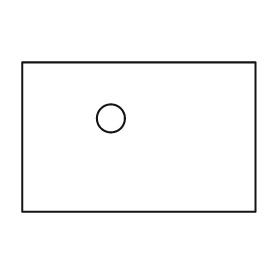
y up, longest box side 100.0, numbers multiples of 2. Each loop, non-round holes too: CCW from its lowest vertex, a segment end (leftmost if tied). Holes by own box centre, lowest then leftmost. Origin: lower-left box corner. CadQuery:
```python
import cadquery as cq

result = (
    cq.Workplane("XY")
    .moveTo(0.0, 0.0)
    .lineTo(100.0, 0.0)
    .lineTo(100.0, 64.0)
    .lineTo(0.0, 64.0)
    .close()
    .moveTo(38.0, 40.0)
    .circle(6.0)
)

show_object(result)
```